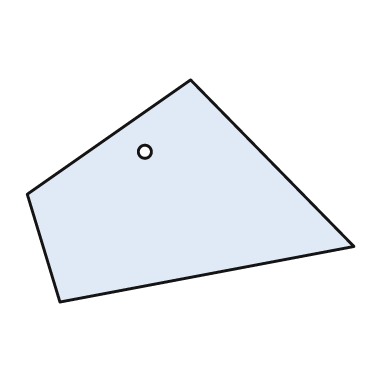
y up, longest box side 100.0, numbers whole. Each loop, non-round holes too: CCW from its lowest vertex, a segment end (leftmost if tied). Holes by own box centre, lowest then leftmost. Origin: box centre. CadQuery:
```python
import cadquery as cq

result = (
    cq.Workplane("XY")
    .moveTo(-40.0, -34.0)
    .lineTo(50.0, -17.0)
    .lineTo(0.0, 34.0)
    .lineTo(-50.0, -1.0)
    .close()
    .moveTo(-14.0, 12.0)
    .circle(2.0)
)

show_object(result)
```